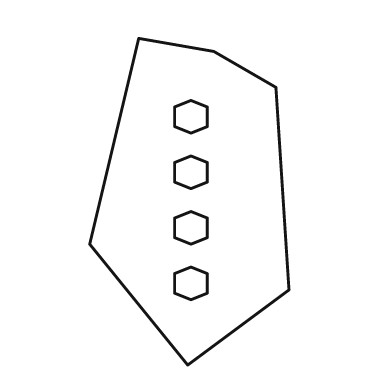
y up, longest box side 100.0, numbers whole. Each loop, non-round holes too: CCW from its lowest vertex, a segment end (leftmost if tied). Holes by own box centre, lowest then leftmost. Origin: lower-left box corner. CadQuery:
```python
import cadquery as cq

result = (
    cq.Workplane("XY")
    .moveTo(30.0, 0.0)
    .lineTo(61.0, 23.0)
    .lineTo(57.0, 85.0)
    .lineTo(38.0, 96.0)
    .lineTo(15.0, 100.0)
    .lineTo(0.0, 37.0)
    .close()
    .moveTo(31.0, 20.0)
    .lineTo(36.0, 22.0)
    .lineTo(36.0, 28.0)
    .lineTo(31.0, 30.0)
    .lineTo(26.0, 28.0)
    .lineTo(26.0, 22.0)
    .close()
    .moveTo(31.0, 37.0)
    .lineTo(36.0, 39.0)
    .lineTo(36.0, 45.0)
    .lineTo(31.0, 47.0)
    .lineTo(26.0, 45.0)
    .lineTo(26.0, 39.0)
    .close()
    .moveTo(31.0, 54.0)
    .lineTo(36.0, 56.0)
    .lineTo(36.0, 62.0)
    .lineTo(31.0, 64.0)
    .lineTo(26.0, 62.0)
    .lineTo(26.0, 56.0)
    .close()
    .moveTo(31.0, 71.0)
    .lineTo(36.0, 73.0)
    .lineTo(36.0, 79.0)
    .lineTo(31.0, 81.0)
    .lineTo(26.0, 79.0)
    .lineTo(26.0, 73.0)
    .close()
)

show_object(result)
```